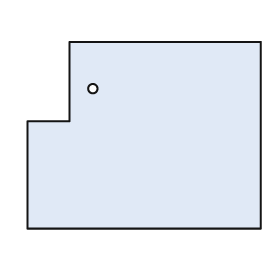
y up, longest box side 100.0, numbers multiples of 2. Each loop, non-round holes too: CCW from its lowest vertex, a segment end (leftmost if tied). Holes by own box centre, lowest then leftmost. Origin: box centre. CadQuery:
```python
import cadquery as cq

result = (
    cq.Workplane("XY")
    .moveTo(-50.0, -40.0)
    .lineTo(50.0, -40.0)
    .lineTo(50.0, 40.0)
    .lineTo(-32.0, 40.0)
    .lineTo(-32.0, 6.0)
    .lineTo(-50.0, 6.0)
    .close()
    .moveTo(-22.0, 20.0)
    .circle(2.0)
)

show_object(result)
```